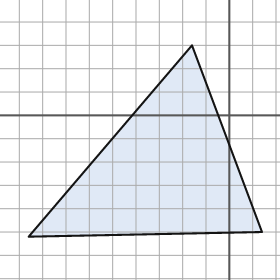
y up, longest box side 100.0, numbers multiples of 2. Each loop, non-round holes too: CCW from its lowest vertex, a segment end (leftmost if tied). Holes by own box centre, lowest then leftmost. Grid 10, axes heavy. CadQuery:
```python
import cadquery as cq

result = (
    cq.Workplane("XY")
    .moveTo(-86.0, -52.0)
    .lineTo(14.0, -50.0)
    .lineTo(-16.0, 30.0)
    .close()
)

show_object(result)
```